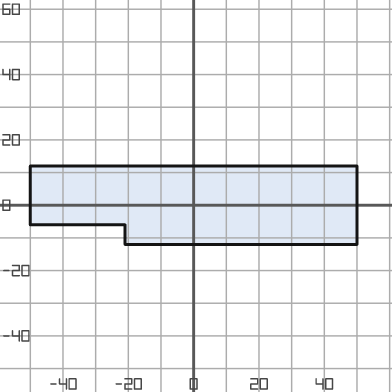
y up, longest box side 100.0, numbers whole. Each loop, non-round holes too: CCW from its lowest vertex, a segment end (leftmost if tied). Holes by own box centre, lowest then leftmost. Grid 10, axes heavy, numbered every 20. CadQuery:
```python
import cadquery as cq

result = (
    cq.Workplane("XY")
    .moveTo(-21.0, -12.0)
    .lineTo(50.0, -12.0)
    .lineTo(50.0, 12.0)
    .lineTo(-50.0, 12.0)
    .lineTo(-50.0, -6.0)
    .lineTo(-21.0, -6.0)
    .close()
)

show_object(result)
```